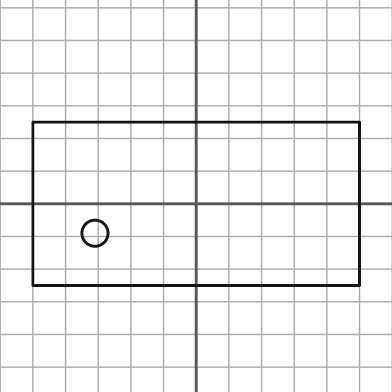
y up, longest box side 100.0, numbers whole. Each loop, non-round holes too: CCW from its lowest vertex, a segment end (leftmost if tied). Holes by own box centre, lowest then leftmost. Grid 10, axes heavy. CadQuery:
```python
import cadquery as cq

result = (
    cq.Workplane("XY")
    .moveTo(-50.0, -25.0)
    .lineTo(50.0, -25.0)
    .lineTo(50.0, 25.0)
    .lineTo(-50.0, 25.0)
    .close()
    .moveTo(-31.0, -9.0)
    .circle(4.0)
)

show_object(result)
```